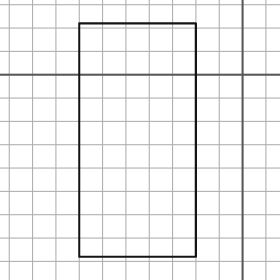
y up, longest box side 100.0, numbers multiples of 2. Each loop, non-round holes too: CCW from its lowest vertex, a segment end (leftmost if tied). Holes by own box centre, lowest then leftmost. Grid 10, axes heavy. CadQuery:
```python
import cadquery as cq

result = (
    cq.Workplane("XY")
    .moveTo(-70.0, -78.0)
    .lineTo(-20.0, -78.0)
    .lineTo(-20.0, 22.0)
    .lineTo(-70.0, 22.0)
    .close()
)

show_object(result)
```